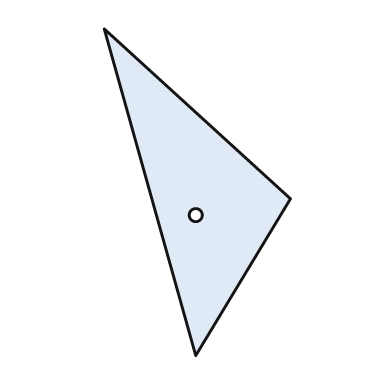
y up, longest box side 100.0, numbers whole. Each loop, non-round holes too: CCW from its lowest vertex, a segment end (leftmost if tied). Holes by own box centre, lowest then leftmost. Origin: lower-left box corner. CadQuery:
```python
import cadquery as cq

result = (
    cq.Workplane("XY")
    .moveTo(28.0, 0.0)
    .lineTo(57.0, 48.0)
    .lineTo(0.0, 100.0)
    .close()
    .moveTo(28.0, 43.0)
    .circle(2.0)
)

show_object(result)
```